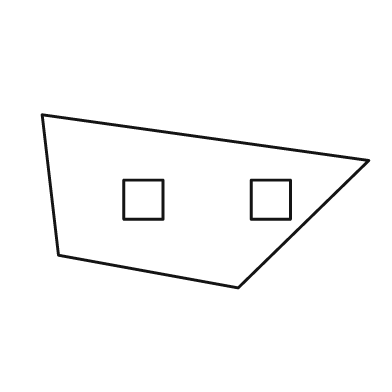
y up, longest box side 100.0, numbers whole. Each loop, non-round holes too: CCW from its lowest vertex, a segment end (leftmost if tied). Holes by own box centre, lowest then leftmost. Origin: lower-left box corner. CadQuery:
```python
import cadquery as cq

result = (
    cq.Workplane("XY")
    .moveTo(60.0, 0.0)
    .lineTo(100.0, 39.0)
    .lineTo(0.0, 53.0)
    .lineTo(5.0, 10.0)
    .close()
    .moveTo(25.0, 21.0)
    .lineTo(37.0, 21.0)
    .lineTo(37.0, 33.0)
    .lineTo(25.0, 33.0)
    .close()
    .moveTo(64.0, 21.0)
    .lineTo(76.0, 21.0)
    .lineTo(76.0, 33.0)
    .lineTo(64.0, 33.0)
    .close()
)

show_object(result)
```